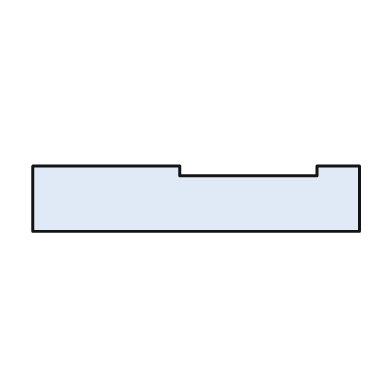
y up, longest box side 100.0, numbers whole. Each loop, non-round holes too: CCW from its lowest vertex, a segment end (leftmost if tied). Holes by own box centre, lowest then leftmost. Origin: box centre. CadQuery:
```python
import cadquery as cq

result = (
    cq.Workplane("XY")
    .moveTo(-50.0, -10.0)
    .lineTo(50.0, -10.0)
    .lineTo(50.0, 10.0)
    .lineTo(37.0, 10.0)
    .lineTo(37.0, 7.0)
    .lineTo(-5.0, 7.0)
    .lineTo(-5.0, 10.0)
    .lineTo(-50.0, 10.0)
    .close()
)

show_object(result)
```